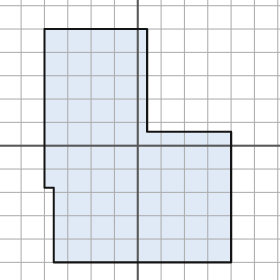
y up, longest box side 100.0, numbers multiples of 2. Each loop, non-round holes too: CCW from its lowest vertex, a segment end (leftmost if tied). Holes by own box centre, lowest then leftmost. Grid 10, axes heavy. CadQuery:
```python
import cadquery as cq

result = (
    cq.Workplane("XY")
    .moveTo(-36.0, -50.0)
    .lineTo(40.0, -50.0)
    .lineTo(40.0, 6.0)
    .lineTo(4.0, 6.0)
    .lineTo(4.0, 50.0)
    .lineTo(-40.0, 50.0)
    .lineTo(-40.0, -18.0)
    .lineTo(-36.0, -18.0)
    .close()
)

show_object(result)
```